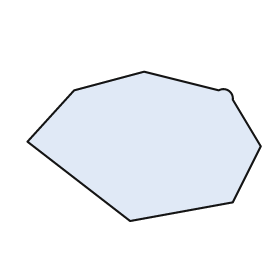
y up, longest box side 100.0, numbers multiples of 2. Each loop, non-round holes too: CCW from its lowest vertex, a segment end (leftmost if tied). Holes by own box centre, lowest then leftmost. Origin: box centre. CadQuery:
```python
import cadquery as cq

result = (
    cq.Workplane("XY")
    .moveTo(-6.0, -32.0)
    .lineTo(38.0, -24.0)
    .lineTo(50.0, 0.0)
    .lineTo(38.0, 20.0)
    .threePointArc((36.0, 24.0), (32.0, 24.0))
    .lineTo(0.0, 32.0)
    .lineTo(-30.0, 24.0)
    .lineTo(-50.0, 2.0)
    .close()
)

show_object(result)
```